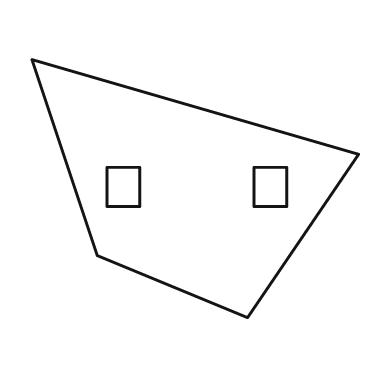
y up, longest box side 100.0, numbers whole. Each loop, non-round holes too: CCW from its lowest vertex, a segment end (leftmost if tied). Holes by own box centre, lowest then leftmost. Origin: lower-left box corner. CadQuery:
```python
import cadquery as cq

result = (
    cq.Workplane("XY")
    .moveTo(66.0, 0.0)
    .lineTo(100.0, 50.0)
    .lineTo(0.0, 79.0)
    .lineTo(20.0, 19.0)
    .close()
    .moveTo(23.0, 34.0)
    .lineTo(33.0, 34.0)
    .lineTo(33.0, 46.0)
    .lineTo(23.0, 46.0)
    .close()
    .moveTo(68.0, 34.0)
    .lineTo(78.0, 34.0)
    .lineTo(78.0, 46.0)
    .lineTo(68.0, 46.0)
    .close()
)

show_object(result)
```